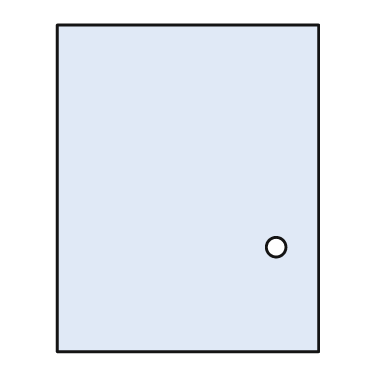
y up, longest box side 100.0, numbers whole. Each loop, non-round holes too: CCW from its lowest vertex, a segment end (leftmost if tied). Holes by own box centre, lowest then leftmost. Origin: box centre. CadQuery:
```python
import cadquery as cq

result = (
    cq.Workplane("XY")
    .moveTo(-40.0, -50.0)
    .lineTo(40.0, -50.0)
    .lineTo(40.0, 50.0)
    .lineTo(-40.0, 50.0)
    .close()
    .moveTo(27.0, -18.0)
    .circle(3.0)
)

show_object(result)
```